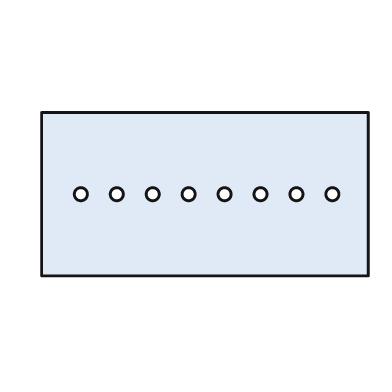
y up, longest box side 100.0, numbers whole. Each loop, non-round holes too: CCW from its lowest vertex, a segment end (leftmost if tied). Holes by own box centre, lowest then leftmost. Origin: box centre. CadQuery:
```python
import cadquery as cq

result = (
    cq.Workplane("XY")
    .moveTo(-50.0, -25.0)
    .lineTo(50.0, -25.0)
    .lineTo(50.0, 25.0)
    .lineTo(-50.0, 25.0)
    .close()
    .moveTo(-38.0, 0.0)
    .circle(2.0)
    .moveTo(-27.0, 0.0)
    .circle(2.0)
    .moveTo(-16.0, 0.0)
    .circle(2.0)
    .moveTo(-5.0, 0.0)
    .circle(2.0)
    .moveTo(6.0, 0.0)
    .circle(2.0)
    .moveTo(17.0, 0.0)
    .circle(2.0)
    .moveTo(28.0, 0.0)
    .circle(2.0)
    .moveTo(39.0, 0.0)
    .circle(2.0)
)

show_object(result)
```